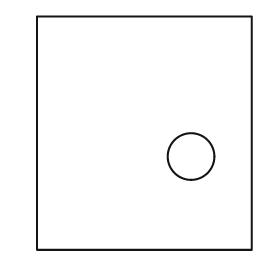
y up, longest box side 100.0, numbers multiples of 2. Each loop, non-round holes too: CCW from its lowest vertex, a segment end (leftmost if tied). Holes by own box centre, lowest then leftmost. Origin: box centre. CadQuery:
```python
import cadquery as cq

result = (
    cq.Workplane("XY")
    .moveTo(-46.0, -50.0)
    .lineTo(46.0, -50.0)
    .lineTo(46.0, 50.0)
    .lineTo(-46.0, 50.0)
    .close()
    .moveTo(20.0, -10.0)
    .circle(10.0)
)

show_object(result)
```